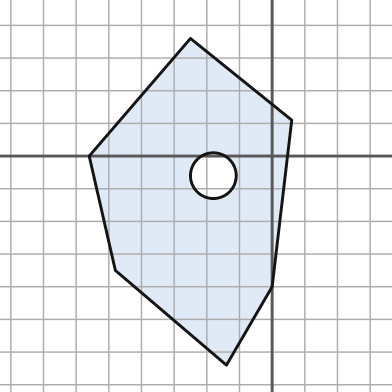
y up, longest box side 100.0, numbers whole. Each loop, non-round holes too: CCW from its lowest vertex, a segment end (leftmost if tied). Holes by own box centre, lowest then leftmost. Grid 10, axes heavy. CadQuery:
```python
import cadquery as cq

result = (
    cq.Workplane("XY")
    .moveTo(-14.0, -64.0)
    .lineTo(0.0, -40.0)
    .lineTo(6.0, 11.0)
    .lineTo(-25.0, 36.0)
    .lineTo(-56.0, 0.0)
    .lineTo(-48.0, -35.0)
    .close()
    .moveTo(-18.0, -6.0)
    .circle(7.0)
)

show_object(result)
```